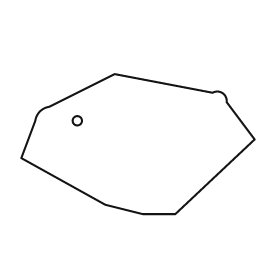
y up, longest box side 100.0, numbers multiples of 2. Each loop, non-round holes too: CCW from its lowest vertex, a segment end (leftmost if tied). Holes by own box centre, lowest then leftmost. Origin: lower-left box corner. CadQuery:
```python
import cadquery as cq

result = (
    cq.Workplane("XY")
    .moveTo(52.0, 0.0)
    .lineTo(66.0, 0.0)
    .lineTo(100.0, 32.0)
    .lineTo(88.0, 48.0)
    .threePointArc((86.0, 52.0), (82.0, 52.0))
    .lineTo(40.0, 60.0)
    .lineTo(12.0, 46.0)
    .threePointArc((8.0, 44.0), (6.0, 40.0))
    .lineTo(0.0, 24.0)
    .lineTo(36.0, 4.0)
    .close()
    .moveTo(24.0, 40.0)
    .circle(2.0)
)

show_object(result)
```